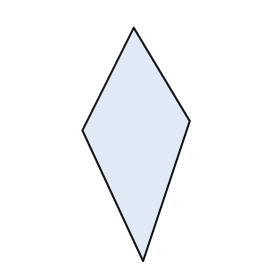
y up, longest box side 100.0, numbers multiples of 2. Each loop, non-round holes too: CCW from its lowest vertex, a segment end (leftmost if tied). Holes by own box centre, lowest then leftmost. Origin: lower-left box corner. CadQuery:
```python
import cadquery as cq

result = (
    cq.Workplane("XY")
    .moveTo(26.0, 0.0)
    .lineTo(46.0, 60.0)
    .lineTo(22.0, 100.0)
    .lineTo(0.0, 56.0)
    .close()
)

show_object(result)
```